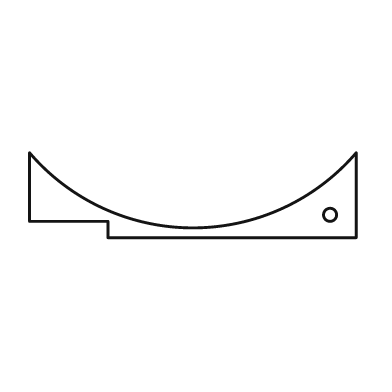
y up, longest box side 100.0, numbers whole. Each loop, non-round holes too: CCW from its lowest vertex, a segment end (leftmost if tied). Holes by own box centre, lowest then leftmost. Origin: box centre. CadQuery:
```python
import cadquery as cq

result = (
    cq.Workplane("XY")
    .moveTo(-26.0, -13.0)
    .lineTo(50.0, -13.0)
    .lineTo(50.0, 13.0)
    .threePointArc((0.0, -10.0), (-50.0, 13.0))
    .lineTo(-50.0, -8.0)
    .lineTo(-26.0, -8.0)
    .close()
    .moveTo(42.0, -6.0)
    .circle(2.0)
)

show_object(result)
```